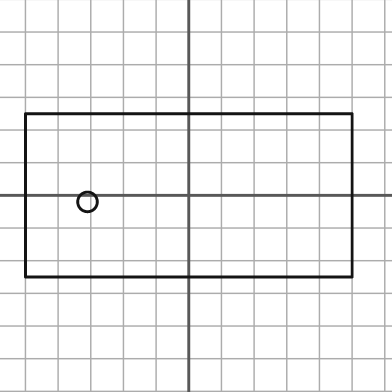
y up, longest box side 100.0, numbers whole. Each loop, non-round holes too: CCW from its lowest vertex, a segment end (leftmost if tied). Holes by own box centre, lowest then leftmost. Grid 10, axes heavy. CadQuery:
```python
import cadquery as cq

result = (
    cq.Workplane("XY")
    .moveTo(-50.0, -25.0)
    .lineTo(50.0, -25.0)
    .lineTo(50.0, 25.0)
    .lineTo(-50.0, 25.0)
    .close()
    .moveTo(-31.0, -2.0)
    .circle(3.0)
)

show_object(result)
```